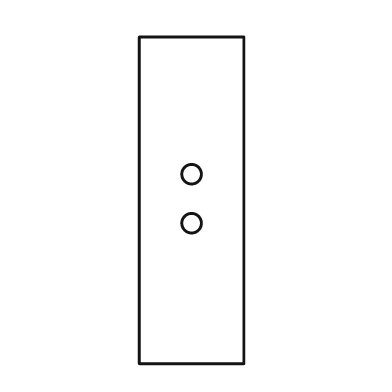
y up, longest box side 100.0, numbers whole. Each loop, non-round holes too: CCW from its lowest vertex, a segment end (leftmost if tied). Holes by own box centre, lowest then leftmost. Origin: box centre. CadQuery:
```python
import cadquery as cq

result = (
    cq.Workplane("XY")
    .moveTo(-16.0, -50.0)
    .lineTo(16.0, -50.0)
    .lineTo(16.0, 50.0)
    .lineTo(-16.0, 50.0)
    .close()
    .moveTo(0.0, -7.0)
    .circle(3.0)
    .moveTo(0.0, 8.0)
    .circle(3.0)
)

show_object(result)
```